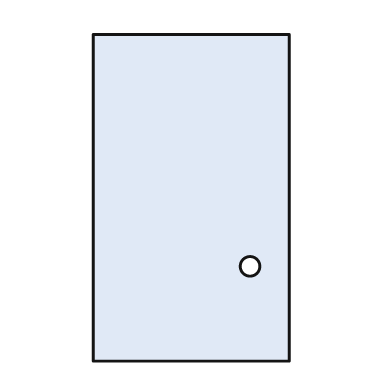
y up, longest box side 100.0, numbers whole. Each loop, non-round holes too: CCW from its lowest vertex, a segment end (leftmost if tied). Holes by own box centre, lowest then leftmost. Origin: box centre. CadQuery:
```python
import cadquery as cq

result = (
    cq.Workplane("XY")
    .moveTo(-30.0, -50.0)
    .lineTo(30.0, -50.0)
    .lineTo(30.0, 50.0)
    .lineTo(-30.0, 50.0)
    .close()
    .moveTo(18.0, -21.0)
    .circle(3.0)
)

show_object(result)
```